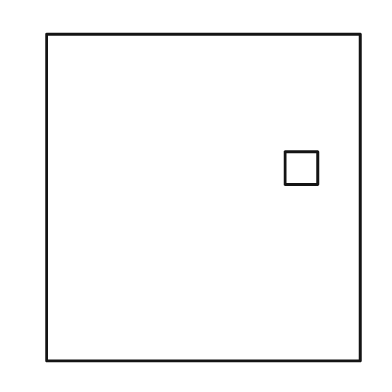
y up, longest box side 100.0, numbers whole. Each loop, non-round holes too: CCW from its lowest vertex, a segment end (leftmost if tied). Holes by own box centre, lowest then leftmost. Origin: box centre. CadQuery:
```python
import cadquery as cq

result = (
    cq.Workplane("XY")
    .moveTo(-48.0, -50.0)
    .lineTo(48.0, -50.0)
    .lineTo(48.0, 50.0)
    .lineTo(-48.0, 50.0)
    .close()
    .moveTo(25.0, 4.0)
    .lineTo(35.0, 4.0)
    .lineTo(35.0, 14.0)
    .lineTo(25.0, 14.0)
    .close()
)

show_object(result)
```